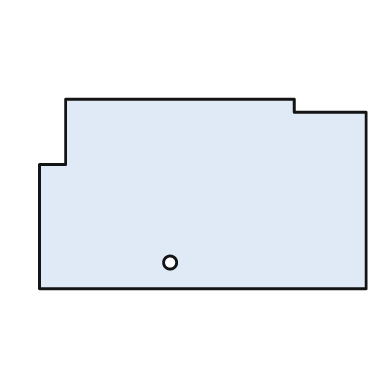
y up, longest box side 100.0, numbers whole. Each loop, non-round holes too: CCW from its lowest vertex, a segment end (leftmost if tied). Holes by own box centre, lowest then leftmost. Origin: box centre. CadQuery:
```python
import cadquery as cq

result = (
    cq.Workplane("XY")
    .moveTo(-50.0, -29.0)
    .lineTo(50.0, -29.0)
    .lineTo(50.0, 25.0)
    .lineTo(28.0, 25.0)
    .lineTo(28.0, 29.0)
    .lineTo(-42.0, 29.0)
    .lineTo(-42.0, 9.0)
    .lineTo(-50.0, 9.0)
    .close()
    .moveTo(-10.0, -21.0)
    .circle(2.0)
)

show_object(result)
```